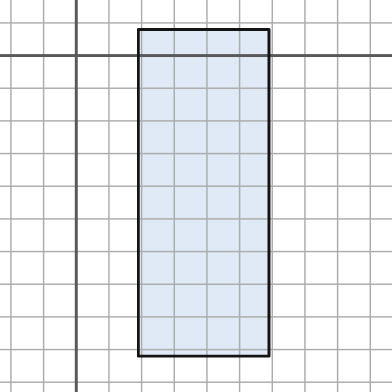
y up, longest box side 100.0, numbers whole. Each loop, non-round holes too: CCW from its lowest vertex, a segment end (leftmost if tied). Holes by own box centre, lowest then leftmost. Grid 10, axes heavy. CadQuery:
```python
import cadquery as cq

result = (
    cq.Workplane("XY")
    .moveTo(19.0, -92.0)
    .lineTo(59.0, -92.0)
    .lineTo(59.0, 8.0)
    .lineTo(19.0, 8.0)
    .close()
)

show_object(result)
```